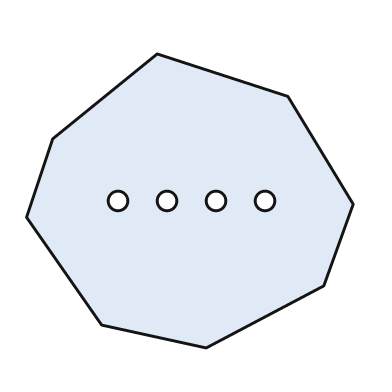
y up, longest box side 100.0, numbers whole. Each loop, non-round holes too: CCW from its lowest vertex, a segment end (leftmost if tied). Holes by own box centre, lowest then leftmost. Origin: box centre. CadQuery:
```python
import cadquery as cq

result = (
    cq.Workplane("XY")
    .moveTo(5.0, -45.0)
    .lineTo(41.0, -26.0)
    .lineTo(50.0, -1.0)
    .lineTo(30.0, 32.0)
    .lineTo(-10.0, 45.0)
    .lineTo(-42.0, 19.0)
    .lineTo(-50.0, -5.0)
    .lineTo(-27.0, -38.0)
    .close()
    .moveTo(-22.0, 0.0)
    .circle(3.0)
    .moveTo(-7.0, 0.0)
    .circle(3.0)
    .moveTo(8.0, 0.0)
    .circle(3.0)
    .moveTo(23.0, 0.0)
    .circle(3.0)
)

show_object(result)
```